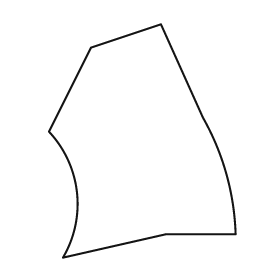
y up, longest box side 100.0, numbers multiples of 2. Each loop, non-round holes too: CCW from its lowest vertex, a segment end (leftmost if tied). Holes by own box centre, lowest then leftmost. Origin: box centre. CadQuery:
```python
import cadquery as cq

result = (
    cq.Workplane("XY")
    .moveTo(-34.0, -50.0)
    .lineTo(10.0, -40.0)
    .lineTo(40.0, -40.0)
    .threePointArc((36.0, -14.0), (26.0, 10.0))
    .lineTo(8.0, 50.0)
    .lineTo(-22.0, 40.0)
    .lineTo(-40.0, 4.0)
    .threePointArc((-28.0, -22.0), (-34.0, -50.0))
    .close()
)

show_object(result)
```